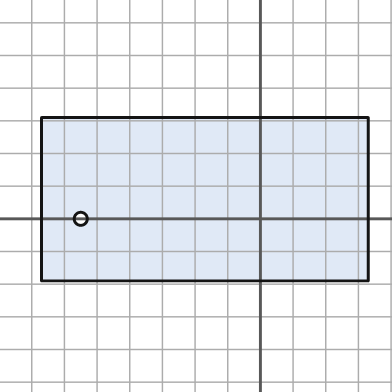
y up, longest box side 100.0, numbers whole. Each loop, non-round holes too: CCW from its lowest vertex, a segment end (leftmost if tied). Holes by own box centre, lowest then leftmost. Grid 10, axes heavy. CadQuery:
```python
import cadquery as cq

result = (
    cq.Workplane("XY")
    .moveTo(-67.0, -19.0)
    .lineTo(33.0, -19.0)
    .lineTo(33.0, 31.0)
    .lineTo(-67.0, 31.0)
    .close()
    .moveTo(-55.0, 0.0)
    .circle(2.0)
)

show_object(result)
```